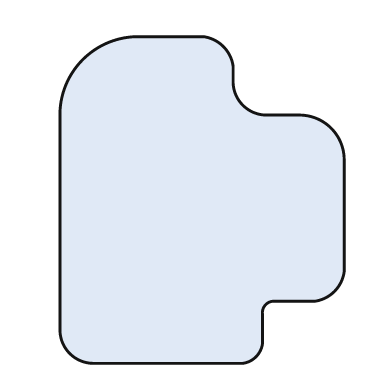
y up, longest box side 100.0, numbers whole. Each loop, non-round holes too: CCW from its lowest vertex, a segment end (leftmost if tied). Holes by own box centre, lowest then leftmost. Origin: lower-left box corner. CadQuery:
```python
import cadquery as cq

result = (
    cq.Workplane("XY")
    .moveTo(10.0, 0.0)
    .lineTo(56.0, 0.0)
    .threePointArc((60.0, 2.0), (62.0, 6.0))
    .lineTo(62.0, 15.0)
    .threePointArc((63.0, 18.0), (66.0, 19.0))
    .lineTo(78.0, 19.0)
    .threePointArc((84.0, 22.0), (87.0, 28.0))
    .lineTo(87.0, 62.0)
    .threePointArc((83.0, 72.0), (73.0, 76.0))
    .lineTo(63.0, 76.0)
    .threePointArc((56.0, 79.0), (53.0, 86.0))
    .lineTo(53.0, 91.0)
    .threePointArc((50.0, 97.0), (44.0, 100.0))
    .lineTo(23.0, 100.0)
    .threePointArc((7.0, 93.0), (0.0, 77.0))
    .lineTo(0.0, 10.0)
    .threePointArc((3.0, 3.0), (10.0, 0.0))
    .close()
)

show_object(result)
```